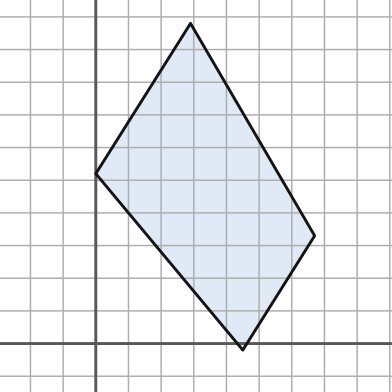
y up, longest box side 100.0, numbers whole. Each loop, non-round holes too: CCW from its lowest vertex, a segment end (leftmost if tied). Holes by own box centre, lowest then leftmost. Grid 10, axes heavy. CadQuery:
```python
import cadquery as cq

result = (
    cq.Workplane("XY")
    .moveTo(45.0, -2.0)
    .lineTo(67.0, 33.0)
    .lineTo(29.0, 98.0)
    .lineTo(0.0, 52.0)
    .close()
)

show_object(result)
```